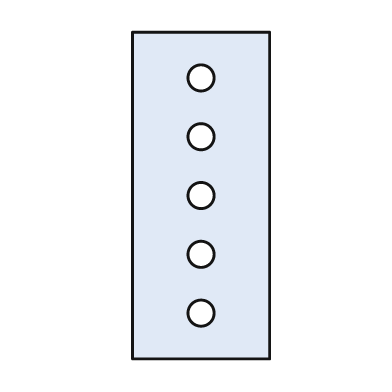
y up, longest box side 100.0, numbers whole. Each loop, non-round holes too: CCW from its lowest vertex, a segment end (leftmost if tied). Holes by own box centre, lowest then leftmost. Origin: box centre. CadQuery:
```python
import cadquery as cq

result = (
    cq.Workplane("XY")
    .moveTo(-21.0, -50.0)
    .lineTo(21.0, -50.0)
    .lineTo(21.0, 50.0)
    .lineTo(-21.0, 50.0)
    .close()
    .moveTo(0.0, -36.0)
    .circle(4.0)
    .moveTo(0.0, -18.0)
    .circle(4.0)
    .moveTo(0.0, 0.0)
    .circle(4.0)
    .moveTo(0.0, 18.0)
    .circle(4.0)
    .moveTo(0.0, 36.0)
    .circle(4.0)
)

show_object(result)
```